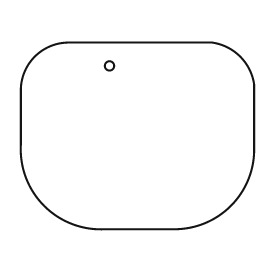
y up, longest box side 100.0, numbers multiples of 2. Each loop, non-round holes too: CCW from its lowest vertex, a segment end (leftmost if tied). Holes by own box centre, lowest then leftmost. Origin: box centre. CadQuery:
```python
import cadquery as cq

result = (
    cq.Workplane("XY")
    .moveTo(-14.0, -40.0)
    .lineTo(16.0, -40.0)
    .threePointArc((40.0, -30.0), (50.0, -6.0))
    .lineTo(50.0, 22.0)
    .threePointArc((44.0, 34.0), (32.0, 40.0))
    .lineTo(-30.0, 40.0)
    .threePointArc((-44.0, 34.0), (-50.0, 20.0))
    .lineTo(-50.0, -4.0)
    .threePointArc((-40.0, -30.0), (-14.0, -40.0))
    .close()
    .moveTo(-12.0, 30.0)
    .circle(2.0)
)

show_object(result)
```